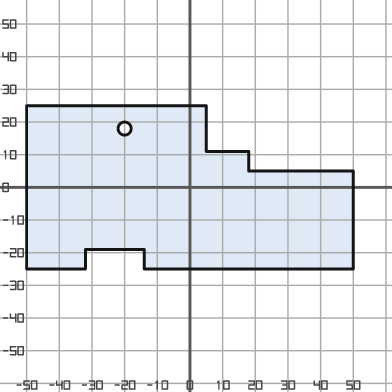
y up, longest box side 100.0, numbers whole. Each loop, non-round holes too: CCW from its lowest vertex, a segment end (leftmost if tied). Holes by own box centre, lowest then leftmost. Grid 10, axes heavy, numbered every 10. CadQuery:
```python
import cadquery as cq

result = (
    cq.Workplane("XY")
    .moveTo(-50.0, -25.0)
    .lineTo(-32.0, -25.0)
    .lineTo(-32.0, -19.0)
    .lineTo(-14.0, -19.0)
    .lineTo(-14.0, -25.0)
    .lineTo(50.0, -25.0)
    .lineTo(50.0, 5.0)
    .lineTo(18.0, 5.0)
    .lineTo(18.0, 11.0)
    .lineTo(5.0, 11.0)
    .lineTo(5.0, 25.0)
    .lineTo(-50.0, 25.0)
    .close()
    .moveTo(-20.0, 18.0)
    .circle(2.0)
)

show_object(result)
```